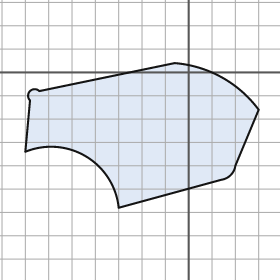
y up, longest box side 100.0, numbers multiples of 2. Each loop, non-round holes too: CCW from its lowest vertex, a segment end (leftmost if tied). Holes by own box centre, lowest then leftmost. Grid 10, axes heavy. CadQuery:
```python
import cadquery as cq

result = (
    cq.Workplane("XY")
    .moveTo(-30.0, -58.0)
    .lineTo(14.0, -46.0)
    .threePointArc((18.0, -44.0), (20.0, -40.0))
    .lineTo(30.0, -16.0)
    .threePointArc((14.0, -2.0), (-6.0, 4.0))
    .lineTo(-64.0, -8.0)
    .threePointArc((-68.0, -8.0), (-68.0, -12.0))
    .lineTo(-70.0, -34.0)
    .threePointArc((-44.0, -36.0), (-30.0, -58.0))
    .close()
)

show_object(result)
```